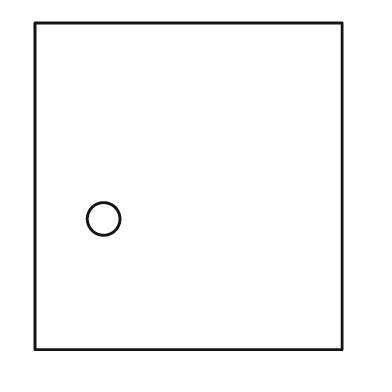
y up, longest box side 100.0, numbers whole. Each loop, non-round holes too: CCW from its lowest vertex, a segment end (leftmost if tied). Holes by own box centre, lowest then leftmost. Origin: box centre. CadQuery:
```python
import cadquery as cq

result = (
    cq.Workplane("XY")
    .moveTo(-47.0, -50.0)
    .lineTo(47.0, -50.0)
    .lineTo(47.0, 50.0)
    .lineTo(-47.0, 50.0)
    .close()
    .moveTo(-26.0, -10.0)
    .circle(5.0)
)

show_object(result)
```